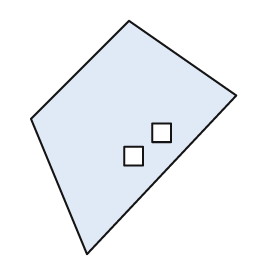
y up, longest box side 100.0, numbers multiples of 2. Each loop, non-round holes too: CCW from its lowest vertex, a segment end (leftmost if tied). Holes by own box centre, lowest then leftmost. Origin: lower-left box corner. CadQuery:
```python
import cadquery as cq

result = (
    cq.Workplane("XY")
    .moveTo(24.0, 0.0)
    .lineTo(88.0, 68.0)
    .lineTo(42.0, 100.0)
    .lineTo(0.0, 58.0)
    .close()
    .moveTo(40.0, 38.0)
    .lineTo(48.0, 38.0)
    .lineTo(48.0, 46.0)
    .lineTo(40.0, 46.0)
    .close()
    .moveTo(52.0, 48.0)
    .lineTo(60.0, 48.0)
    .lineTo(60.0, 56.0)
    .lineTo(52.0, 56.0)
    .close()
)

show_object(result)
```